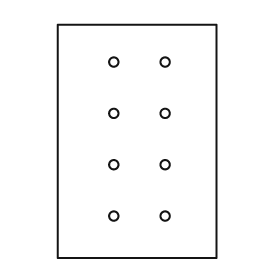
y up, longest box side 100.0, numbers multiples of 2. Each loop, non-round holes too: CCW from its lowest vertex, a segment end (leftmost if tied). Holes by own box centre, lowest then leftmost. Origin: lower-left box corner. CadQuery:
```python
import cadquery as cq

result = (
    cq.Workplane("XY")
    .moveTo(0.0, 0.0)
    .lineTo(68.0, 0.0)
    .lineTo(68.0, 100.0)
    .lineTo(0.0, 100.0)
    .close()
    .moveTo(24.0, 18.0)
    .circle(2.0)
    .moveTo(46.0, 18.0)
    .circle(2.0)
    .moveTo(24.0, 40.0)
    .circle(2.0)
    .moveTo(46.0, 40.0)
    .circle(2.0)
    .moveTo(24.0, 62.0)
    .circle(2.0)
    .moveTo(46.0, 62.0)
    .circle(2.0)
    .moveTo(24.0, 84.0)
    .circle(2.0)
    .moveTo(46.0, 84.0)
    .circle(2.0)
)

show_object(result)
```